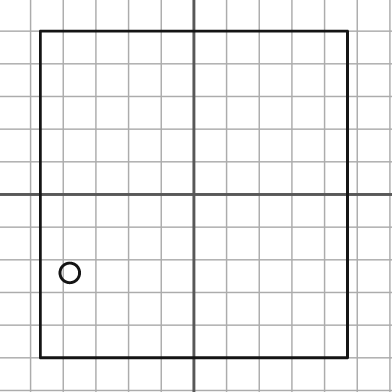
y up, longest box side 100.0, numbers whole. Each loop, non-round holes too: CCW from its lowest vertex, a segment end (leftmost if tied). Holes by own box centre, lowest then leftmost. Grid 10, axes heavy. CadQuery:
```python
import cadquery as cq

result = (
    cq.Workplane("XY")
    .moveTo(-47.0, -50.0)
    .lineTo(47.0, -50.0)
    .lineTo(47.0, 50.0)
    .lineTo(-47.0, 50.0)
    .close()
    .moveTo(-38.0, -24.0)
    .circle(3.0)
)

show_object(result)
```